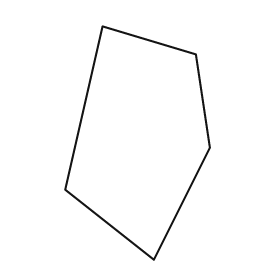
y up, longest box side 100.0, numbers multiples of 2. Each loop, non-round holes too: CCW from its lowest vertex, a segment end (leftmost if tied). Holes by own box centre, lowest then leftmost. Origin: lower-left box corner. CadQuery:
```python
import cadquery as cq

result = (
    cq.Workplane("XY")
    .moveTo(38.0, 0.0)
    .lineTo(62.0, 48.0)
    .lineTo(56.0, 88.0)
    .lineTo(16.0, 100.0)
    .lineTo(0.0, 30.0)
    .close()
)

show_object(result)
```